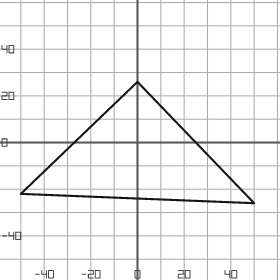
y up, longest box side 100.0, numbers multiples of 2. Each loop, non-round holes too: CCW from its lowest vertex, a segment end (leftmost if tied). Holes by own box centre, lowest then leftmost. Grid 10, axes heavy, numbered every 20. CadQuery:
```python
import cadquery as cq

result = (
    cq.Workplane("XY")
    .moveTo(50.0, -26.0)
    .lineTo(0.0, 26.0)
    .lineTo(-50.0, -22.0)
    .close()
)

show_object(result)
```